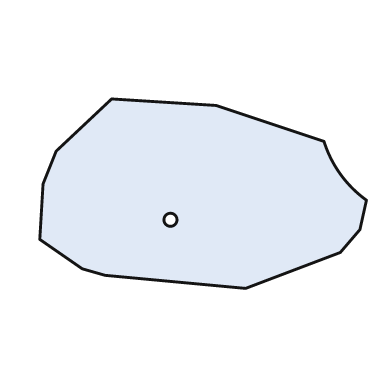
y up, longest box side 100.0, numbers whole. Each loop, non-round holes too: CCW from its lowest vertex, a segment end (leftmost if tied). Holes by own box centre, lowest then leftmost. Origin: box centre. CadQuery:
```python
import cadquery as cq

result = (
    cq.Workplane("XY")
    .moveTo(13.0, -29.0)
    .lineTo(42.0, -18.0)
    .lineTo(48.0, -11.0)
    .lineTo(50.0, -2.0)
    .threePointArc((42.0, 6.0), (37.0, 16.0))
    .lineTo(4.0, 27.0)
    .lineTo(-28.0, 29.0)
    .lineTo(-45.0, 13.0)
    .lineTo(-49.0, 3.0)
    .lineTo(-50.0, -14.0)
    .lineTo(-37.0, -23.0)
    .lineTo(-30.0, -25.0)
    .close()
    .moveTo(-10.0, -8.0)
    .circle(2.0)
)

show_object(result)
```